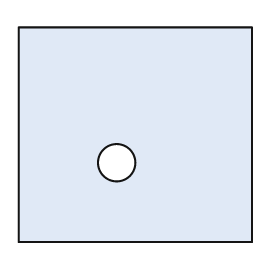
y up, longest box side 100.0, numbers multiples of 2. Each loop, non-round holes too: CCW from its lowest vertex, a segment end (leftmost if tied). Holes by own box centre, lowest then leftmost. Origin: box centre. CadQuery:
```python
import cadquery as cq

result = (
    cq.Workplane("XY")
    .moveTo(-50.0, -46.0)
    .lineTo(50.0, -46.0)
    .lineTo(50.0, 46.0)
    .lineTo(-50.0, 46.0)
    .close()
    .moveTo(-8.0, -12.0)
    .circle(8.0)
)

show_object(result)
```